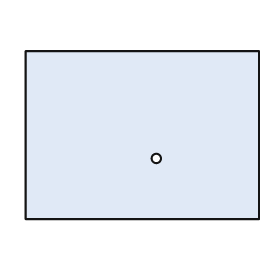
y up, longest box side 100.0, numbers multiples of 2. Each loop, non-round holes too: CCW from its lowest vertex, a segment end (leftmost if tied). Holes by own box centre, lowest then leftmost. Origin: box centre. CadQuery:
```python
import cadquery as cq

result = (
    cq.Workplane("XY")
    .moveTo(-50.0, -36.0)
    .lineTo(50.0, -36.0)
    .lineTo(50.0, 36.0)
    .lineTo(-50.0, 36.0)
    .close()
    .moveTo(6.0, -10.0)
    .circle(2.0)
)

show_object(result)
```